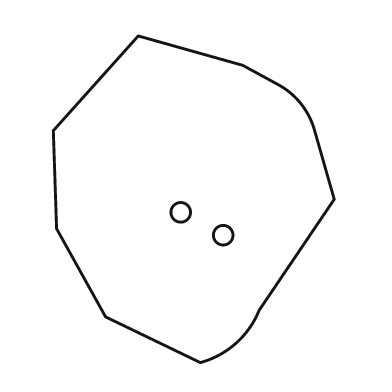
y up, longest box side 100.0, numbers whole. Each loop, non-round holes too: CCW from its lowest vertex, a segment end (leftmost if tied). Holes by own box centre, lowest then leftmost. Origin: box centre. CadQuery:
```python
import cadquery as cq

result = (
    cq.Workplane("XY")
    .moveTo(2.0, -50.0)
    .threePointArc((13.0, -44.0), (20.0, -34.0))
    .lineTo(43.0, 0.0)
    .lineTo(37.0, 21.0)
    .threePointArc((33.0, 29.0), (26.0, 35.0))
    .lineTo(15.0, 41.0)
    .lineTo(-17.0, 50.0)
    .lineTo(-43.0, 21.0)
    .lineTo(-42.0, -9.0)
    .lineTo(-27.0, -36.0)
    .close()
    .moveTo(9.0, -11.0)
    .circle(3.0)
    .moveTo(-4.0, -4.0)
    .circle(3.0)
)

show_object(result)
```